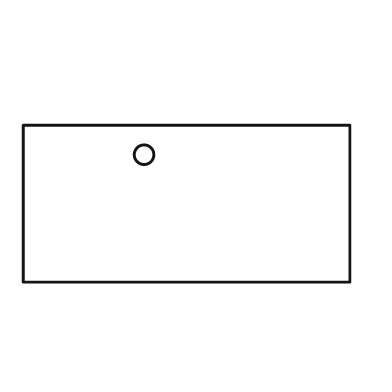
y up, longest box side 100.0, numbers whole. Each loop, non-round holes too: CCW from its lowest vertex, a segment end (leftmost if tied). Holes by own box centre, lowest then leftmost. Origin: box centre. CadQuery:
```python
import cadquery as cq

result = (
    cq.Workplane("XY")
    .moveTo(-50.0, -24.0)
    .lineTo(50.0, -24.0)
    .lineTo(50.0, 24.0)
    .lineTo(-50.0, 24.0)
    .close()
    .moveTo(-13.0, 15.0)
    .circle(3.0)
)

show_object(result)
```